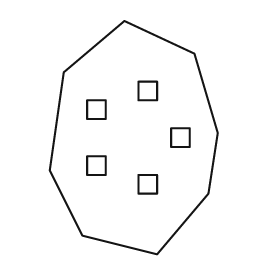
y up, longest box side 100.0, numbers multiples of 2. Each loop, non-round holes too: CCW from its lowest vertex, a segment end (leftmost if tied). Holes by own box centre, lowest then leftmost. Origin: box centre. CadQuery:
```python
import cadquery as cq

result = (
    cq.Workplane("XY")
    .moveTo(10.0, -50.0)
    .lineTo(32.0, -24.0)
    .lineTo(36.0, 2.0)
    .lineTo(26.0, 36.0)
    .lineTo(-4.0, 50.0)
    .lineTo(-30.0, 28.0)
    .lineTo(-36.0, -14.0)
    .lineTo(-22.0, -42.0)
    .close()
    .moveTo(2.0, -24.0)
    .lineTo(10.0, -24.0)
    .lineTo(10.0, -16.0)
    .lineTo(2.0, -16.0)
    .close()
    .moveTo(-20.0, -16.0)
    .lineTo(-12.0, -16.0)
    .lineTo(-12.0, -8.0)
    .lineTo(-20.0, -8.0)
    .close()
    .moveTo(16.0, -4.0)
    .lineTo(24.0, -4.0)
    .lineTo(24.0, 4.0)
    .lineTo(16.0, 4.0)
    .close()
    .moveTo(-20.0, 8.0)
    .lineTo(-12.0, 8.0)
    .lineTo(-12.0, 16.0)
    .lineTo(-20.0, 16.0)
    .close()
    .moveTo(2.0, 16.0)
    .lineTo(10.0, 16.0)
    .lineTo(10.0, 24.0)
    .lineTo(2.0, 24.0)
    .close()
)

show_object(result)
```